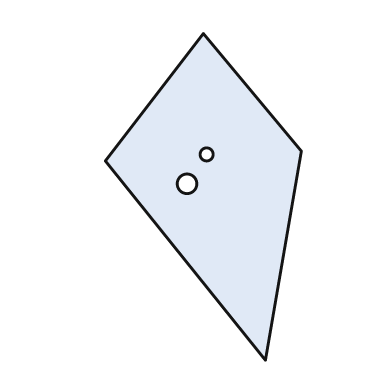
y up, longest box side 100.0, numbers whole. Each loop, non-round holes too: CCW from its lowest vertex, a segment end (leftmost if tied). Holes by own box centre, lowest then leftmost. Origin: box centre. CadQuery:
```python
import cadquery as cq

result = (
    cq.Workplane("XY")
    .moveTo(19.0, -50.0)
    .lineTo(30.0, 14.0)
    .lineTo(0.0, 50.0)
    .lineTo(-30.0, 11.0)
    .close()
    .moveTo(-5.0, 4.0)
    .circle(3.0)
    .moveTo(1.0, 13.0)
    .circle(2.0)
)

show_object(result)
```